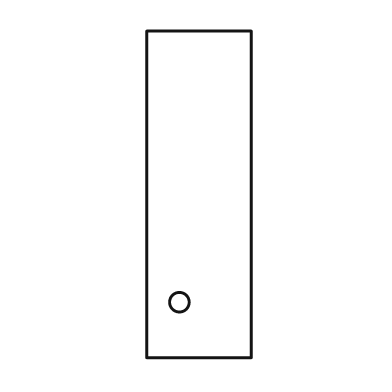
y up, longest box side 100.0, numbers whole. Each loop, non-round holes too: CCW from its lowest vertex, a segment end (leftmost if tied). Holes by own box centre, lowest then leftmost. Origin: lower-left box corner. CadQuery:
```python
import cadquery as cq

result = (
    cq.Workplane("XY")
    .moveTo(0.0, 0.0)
    .lineTo(32.0, 0.0)
    .lineTo(32.0, 100.0)
    .lineTo(0.0, 100.0)
    .close()
    .moveTo(10.0, 17.0)
    .circle(3.0)
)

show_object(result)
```